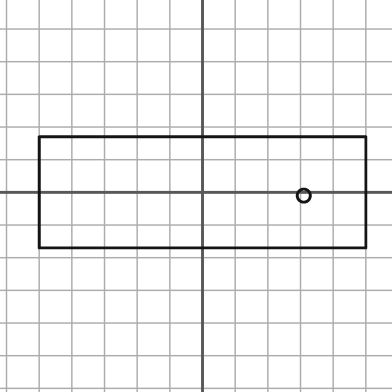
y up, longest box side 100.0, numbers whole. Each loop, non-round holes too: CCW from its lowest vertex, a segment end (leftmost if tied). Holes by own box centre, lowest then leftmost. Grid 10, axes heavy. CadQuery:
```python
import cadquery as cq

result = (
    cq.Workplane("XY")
    .moveTo(-50.0, -17.0)
    .lineTo(50.0, -17.0)
    .lineTo(50.0, 17.0)
    .lineTo(-50.0, 17.0)
    .close()
    .moveTo(31.0, -1.0)
    .circle(2.0)
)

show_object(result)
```